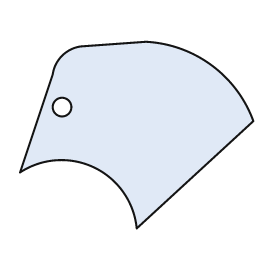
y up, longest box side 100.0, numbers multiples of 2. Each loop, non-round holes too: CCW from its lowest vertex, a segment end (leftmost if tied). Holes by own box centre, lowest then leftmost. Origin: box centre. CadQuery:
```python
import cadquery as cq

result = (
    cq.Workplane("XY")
    .moveTo(0.0, -40.0)
    .lineTo(50.0, 6.0)
    .threePointArc((32.0, 30.0), (4.0, 40.0))
    .lineTo(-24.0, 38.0)
    .threePointArc((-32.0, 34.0), (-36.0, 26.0))
    .lineTo(-50.0, -16.0)
    .threePointArc((-18.0, -14.0), (0.0, -40.0))
    .close()
    .moveTo(-32.0, 12.0)
    .circle(4.0)
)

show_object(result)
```